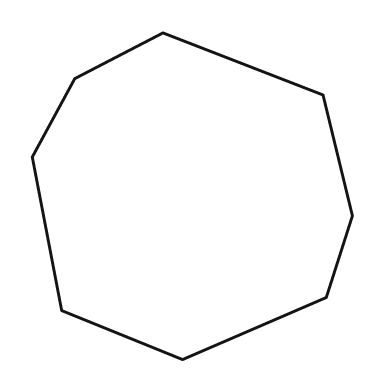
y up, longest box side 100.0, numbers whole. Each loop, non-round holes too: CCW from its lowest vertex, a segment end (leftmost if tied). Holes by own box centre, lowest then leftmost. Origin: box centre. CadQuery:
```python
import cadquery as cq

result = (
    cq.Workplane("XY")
    .moveTo(-3.0, -50.0)
    .lineTo(41.0, -31.0)
    .lineTo(49.0, -6.0)
    .lineTo(40.0, 31.0)
    .lineTo(-9.0, 50.0)
    .lineTo(-36.0, 36.0)
    .lineTo(-49.0, 12.0)
    .lineTo(-40.0, -35.0)
    .close()
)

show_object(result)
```